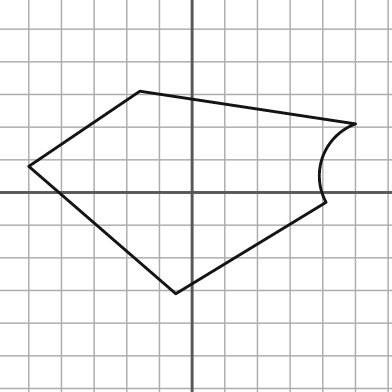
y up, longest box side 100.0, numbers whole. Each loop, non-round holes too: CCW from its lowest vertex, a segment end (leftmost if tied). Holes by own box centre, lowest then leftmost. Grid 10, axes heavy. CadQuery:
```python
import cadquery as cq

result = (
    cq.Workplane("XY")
    .moveTo(-5.0, -31.0)
    .lineTo(41.0, -3.0)
    .threePointArc((40.0, 11.0), (50.0, 21.0))
    .lineTo(-16.0, 31.0)
    .lineTo(-50.0, 8.0)
    .close()
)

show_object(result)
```